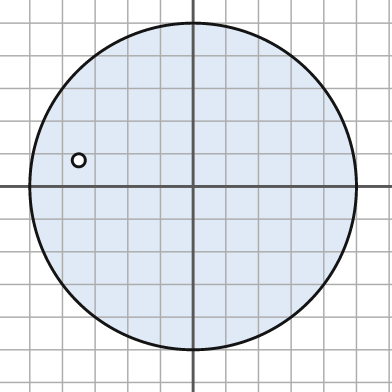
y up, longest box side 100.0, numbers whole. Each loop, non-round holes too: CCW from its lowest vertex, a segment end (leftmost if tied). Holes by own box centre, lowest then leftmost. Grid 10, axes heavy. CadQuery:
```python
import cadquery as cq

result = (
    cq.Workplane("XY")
    .moveTo(0.0, 0.0)
    .circle(50.0)
    .moveTo(-35.0, 8.0)
    .circle(2.0)
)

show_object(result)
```